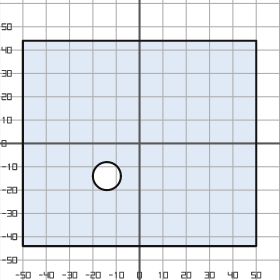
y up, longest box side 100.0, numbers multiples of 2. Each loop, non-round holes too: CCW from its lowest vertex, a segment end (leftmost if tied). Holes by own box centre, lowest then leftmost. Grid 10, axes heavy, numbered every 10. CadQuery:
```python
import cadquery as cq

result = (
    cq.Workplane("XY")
    .moveTo(-50.0, -44.0)
    .lineTo(50.0, -44.0)
    .lineTo(50.0, 44.0)
    .lineTo(-50.0, 44.0)
    .close()
    .moveTo(-14.0, -14.0)
    .circle(6.0)
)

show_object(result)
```